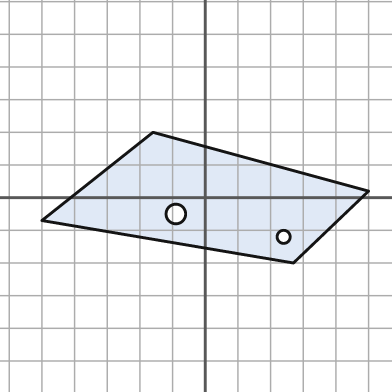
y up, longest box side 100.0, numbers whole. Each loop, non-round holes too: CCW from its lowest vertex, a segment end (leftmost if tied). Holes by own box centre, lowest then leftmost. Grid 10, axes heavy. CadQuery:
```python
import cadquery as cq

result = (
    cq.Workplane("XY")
    .moveTo(27.0, -20.0)
    .lineTo(50.0, 2.0)
    .lineTo(-16.0, 20.0)
    .lineTo(-50.0, -7.0)
    .close()
    .moveTo(24.0, -12.0)
    .circle(2.0)
    .moveTo(-9.0, -5.0)
    .circle(3.0)
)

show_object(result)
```